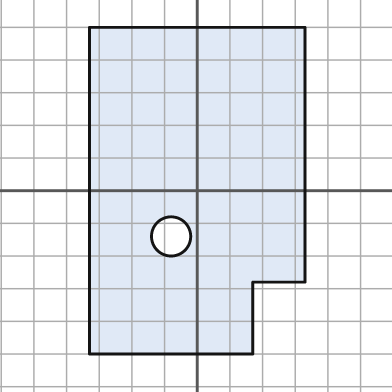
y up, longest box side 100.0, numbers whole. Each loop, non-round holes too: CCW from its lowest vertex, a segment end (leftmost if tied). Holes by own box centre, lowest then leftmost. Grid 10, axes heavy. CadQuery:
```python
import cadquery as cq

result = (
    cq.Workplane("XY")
    .moveTo(-33.0, -50.0)
    .lineTo(17.0, -50.0)
    .lineTo(17.0, -28.0)
    .lineTo(33.0, -28.0)
    .lineTo(33.0, 50.0)
    .lineTo(-33.0, 50.0)
    .close()
    .moveTo(-8.0, -14.0)
    .circle(6.0)
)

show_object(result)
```